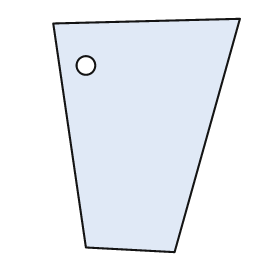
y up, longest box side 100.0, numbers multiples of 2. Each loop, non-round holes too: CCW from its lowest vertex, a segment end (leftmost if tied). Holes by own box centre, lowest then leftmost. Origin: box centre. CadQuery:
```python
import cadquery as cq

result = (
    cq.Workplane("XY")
    .moveTo(12.0, -50.0)
    .lineTo(40.0, 50.0)
    .lineTo(-40.0, 48.0)
    .lineTo(-26.0, -48.0)
    .close()
    .moveTo(-26.0, 30.0)
    .circle(4.0)
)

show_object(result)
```